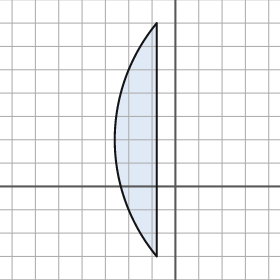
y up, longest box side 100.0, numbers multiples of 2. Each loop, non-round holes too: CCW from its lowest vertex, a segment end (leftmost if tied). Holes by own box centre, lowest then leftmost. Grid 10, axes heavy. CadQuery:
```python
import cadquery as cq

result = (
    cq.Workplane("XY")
    .moveTo(-8.0, -30.0)
    .lineTo(-8.0, 70.0)
    .threePointArc((-26.0, 20.0), (-8.0, -30.0))
    .close()
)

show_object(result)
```